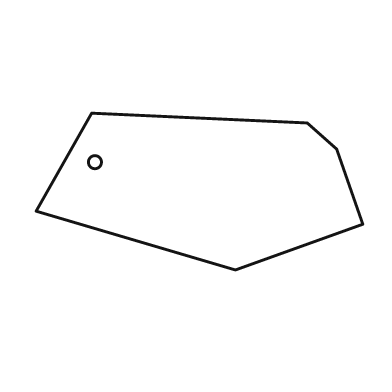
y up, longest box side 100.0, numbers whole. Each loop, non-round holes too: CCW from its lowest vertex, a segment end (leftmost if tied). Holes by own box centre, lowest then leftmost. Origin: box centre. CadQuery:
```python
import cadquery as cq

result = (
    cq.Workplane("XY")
    .moveTo(11.0, -24.0)
    .lineTo(50.0, -10.0)
    .lineTo(42.0, 13.0)
    .lineTo(33.0, 21.0)
    .lineTo(-33.0, 24.0)
    .lineTo(-50.0, -6.0)
    .close()
    .moveTo(-32.0, 9.0)
    .circle(2.0)
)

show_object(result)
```